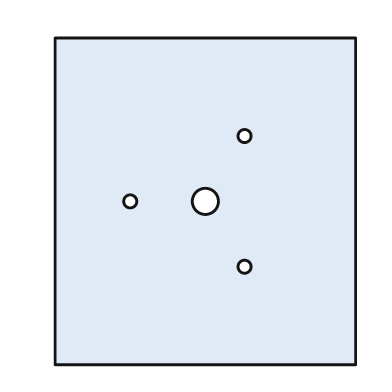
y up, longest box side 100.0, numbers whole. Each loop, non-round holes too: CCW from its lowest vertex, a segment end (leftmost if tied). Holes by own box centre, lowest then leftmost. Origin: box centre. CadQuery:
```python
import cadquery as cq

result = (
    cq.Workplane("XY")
    .moveTo(-46.0, -50.0)
    .lineTo(46.0, -50.0)
    .lineTo(46.0, 50.0)
    .lineTo(-46.0, 50.0)
    .close()
    .moveTo(12.0, -20.0)
    .circle(2.0)
    .moveTo(-23.0, 0.0)
    .circle(2.0)
    .moveTo(0.0, 0.0)
    .circle(4.0)
    .moveTo(12.0, 20.0)
    .circle(2.0)
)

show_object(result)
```